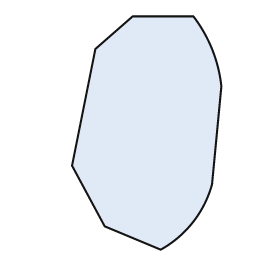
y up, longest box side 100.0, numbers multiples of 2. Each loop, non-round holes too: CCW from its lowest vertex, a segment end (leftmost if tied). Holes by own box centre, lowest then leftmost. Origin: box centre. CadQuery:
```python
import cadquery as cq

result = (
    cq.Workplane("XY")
    .moveTo(6.0, -50.0)
    .threePointArc((20.0, -38.0), (28.0, -22.0))
    .lineTo(32.0, 20.0)
    .threePointArc((28.0, 36.0), (20.0, 50.0))
    .lineTo(-6.0, 50.0)
    .lineTo(-22.0, 36.0)
    .lineTo(-32.0, -14.0)
    .lineTo(-18.0, -40.0)
    .close()
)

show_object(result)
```